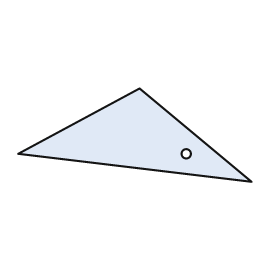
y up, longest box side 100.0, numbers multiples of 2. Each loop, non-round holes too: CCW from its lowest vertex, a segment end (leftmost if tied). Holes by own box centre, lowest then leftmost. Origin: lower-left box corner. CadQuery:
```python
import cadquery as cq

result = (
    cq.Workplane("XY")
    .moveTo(100.0, 0.0)
    .lineTo(52.0, 40.0)
    .lineTo(0.0, 12.0)
    .close()
    .moveTo(72.0, 12.0)
    .circle(2.0)
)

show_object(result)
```